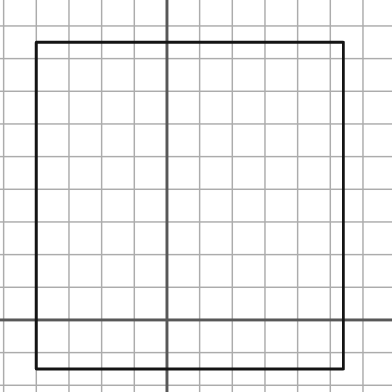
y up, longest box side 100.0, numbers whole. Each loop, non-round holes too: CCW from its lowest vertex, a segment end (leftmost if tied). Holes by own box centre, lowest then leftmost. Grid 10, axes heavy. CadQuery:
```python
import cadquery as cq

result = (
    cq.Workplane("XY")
    .moveTo(-40.0, -15.0)
    .lineTo(54.0, -15.0)
    .lineTo(54.0, 85.0)
    .lineTo(-40.0, 85.0)
    .close()
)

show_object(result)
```